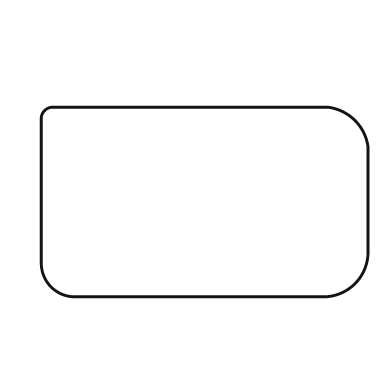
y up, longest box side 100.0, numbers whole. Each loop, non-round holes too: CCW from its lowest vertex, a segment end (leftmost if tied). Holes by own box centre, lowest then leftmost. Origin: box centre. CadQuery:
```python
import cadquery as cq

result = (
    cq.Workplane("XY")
    .moveTo(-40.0, -29.0)
    .lineTo(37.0, -29.0)
    .threePointArc((46.0, -25.0), (50.0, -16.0))
    .lineTo(50.0, 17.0)
    .threePointArc((46.0, 25.0), (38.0, 29.0))
    .lineTo(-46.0, 29.0)
    .threePointArc((-49.0, 28.0), (-50.0, 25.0))
    .lineTo(-50.0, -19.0)
    .threePointArc((-47.0, -26.0), (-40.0, -29.0))
    .close()
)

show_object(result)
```